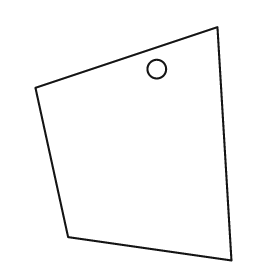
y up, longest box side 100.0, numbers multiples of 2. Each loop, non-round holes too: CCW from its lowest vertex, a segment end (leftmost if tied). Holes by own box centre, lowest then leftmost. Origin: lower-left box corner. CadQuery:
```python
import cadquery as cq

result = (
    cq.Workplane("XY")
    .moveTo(84.0, 0.0)
    .lineTo(78.0, 100.0)
    .lineTo(0.0, 74.0)
    .lineTo(14.0, 10.0)
    .close()
    .moveTo(52.0, 82.0)
    .circle(4.0)
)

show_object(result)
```